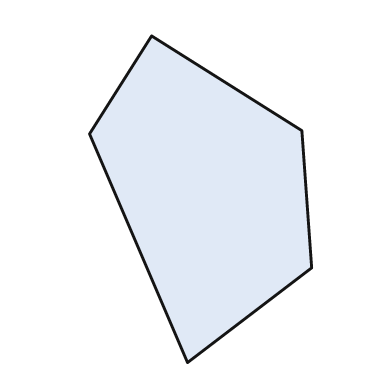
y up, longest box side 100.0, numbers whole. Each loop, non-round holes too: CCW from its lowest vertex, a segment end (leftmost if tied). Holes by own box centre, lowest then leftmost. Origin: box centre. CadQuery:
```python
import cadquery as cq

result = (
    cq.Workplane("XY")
    .moveTo(-4.0, -50.0)
    .lineTo(34.0, -21.0)
    .lineTo(31.0, 21.0)
    .lineTo(-15.0, 50.0)
    .lineTo(-34.0, 20.0)
    .close()
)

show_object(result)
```